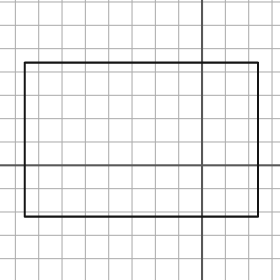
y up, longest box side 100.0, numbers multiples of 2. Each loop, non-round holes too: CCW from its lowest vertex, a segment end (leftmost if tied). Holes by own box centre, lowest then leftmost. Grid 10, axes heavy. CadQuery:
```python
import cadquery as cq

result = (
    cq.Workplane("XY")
    .moveTo(-76.0, -22.0)
    .lineTo(24.0, -22.0)
    .lineTo(24.0, 44.0)
    .lineTo(-76.0, 44.0)
    .close()
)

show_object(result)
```